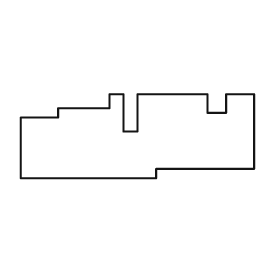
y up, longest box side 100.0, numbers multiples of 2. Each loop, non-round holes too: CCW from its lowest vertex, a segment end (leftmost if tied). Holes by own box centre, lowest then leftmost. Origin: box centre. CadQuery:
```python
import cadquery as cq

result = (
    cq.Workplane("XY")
    .moveTo(-50.0, -18.0)
    .lineTo(8.0, -18.0)
    .lineTo(8.0, -14.0)
    .lineTo(50.0, -14.0)
    .lineTo(50.0, 18.0)
    .lineTo(38.0, 18.0)
    .lineTo(38.0, 10.0)
    .lineTo(30.0, 10.0)
    .lineTo(30.0, 18.0)
    .lineTo(0.0, 18.0)
    .lineTo(0.0, 2.0)
    .lineTo(-6.0, 2.0)
    .lineTo(-6.0, 18.0)
    .lineTo(-12.0, 18.0)
    .lineTo(-12.0, 12.0)
    .lineTo(-34.0, 12.0)
    .lineTo(-34.0, 8.0)
    .lineTo(-50.0, 8.0)
    .close()
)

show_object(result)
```